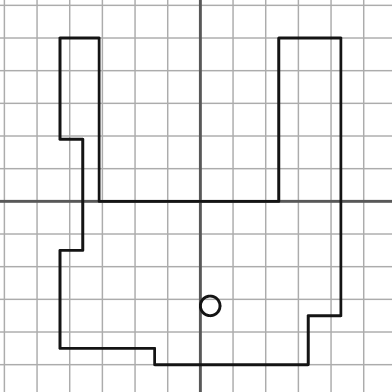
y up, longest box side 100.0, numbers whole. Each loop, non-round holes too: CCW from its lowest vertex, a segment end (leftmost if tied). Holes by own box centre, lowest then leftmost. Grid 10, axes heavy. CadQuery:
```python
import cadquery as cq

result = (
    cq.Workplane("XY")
    .moveTo(-14.0, -50.0)
    .lineTo(33.0, -50.0)
    .lineTo(33.0, -35.0)
    .lineTo(43.0, -35.0)
    .lineTo(43.0, 50.0)
    .lineTo(24.0, 50.0)
    .lineTo(24.0, 0.0)
    .lineTo(-31.0, 0.0)
    .lineTo(-31.0, 50.0)
    .lineTo(-43.0, 50.0)
    .lineTo(-43.0, 19.0)
    .lineTo(-36.0, 19.0)
    .lineTo(-36.0, -15.0)
    .lineTo(-43.0, -15.0)
    .lineTo(-43.0, -45.0)
    .lineTo(-14.0, -45.0)
    .close()
    .moveTo(3.0, -32.0)
    .circle(3.0)
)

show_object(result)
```